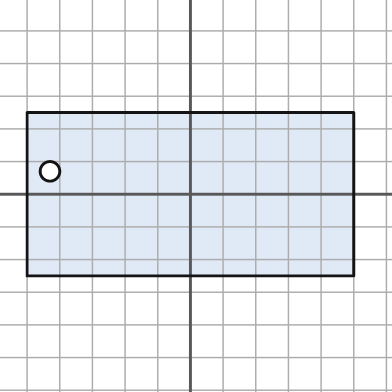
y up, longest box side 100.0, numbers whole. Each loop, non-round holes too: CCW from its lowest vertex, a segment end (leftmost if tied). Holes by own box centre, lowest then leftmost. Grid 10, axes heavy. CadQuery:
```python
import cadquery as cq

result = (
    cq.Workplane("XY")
    .moveTo(-50.0, -25.0)
    .lineTo(50.0, -25.0)
    .lineTo(50.0, 25.0)
    .lineTo(-50.0, 25.0)
    .close()
    .moveTo(-43.0, 7.0)
    .circle(3.0)
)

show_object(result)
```